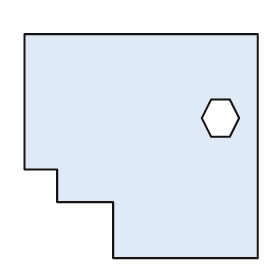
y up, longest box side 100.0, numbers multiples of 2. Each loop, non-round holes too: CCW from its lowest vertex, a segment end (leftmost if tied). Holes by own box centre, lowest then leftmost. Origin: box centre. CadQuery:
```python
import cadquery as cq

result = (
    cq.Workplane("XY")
    .moveTo(-12.0, -48.0)
    .lineTo(50.0, -48.0)
    .lineTo(50.0, 48.0)
    .lineTo(-50.0, 48.0)
    .lineTo(-50.0, -10.0)
    .lineTo(-36.0, -10.0)
    .lineTo(-36.0, -24.0)
    .lineTo(-12.0, -24.0)
    .close()
    .moveTo(30.0, 4.0)
    .lineTo(38.0, 4.0)
    .lineTo(42.0, 12.0)
    .lineTo(38.0, 20.0)
    .lineTo(30.0, 20.0)
    .lineTo(26.0, 12.0)
    .close()
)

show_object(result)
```